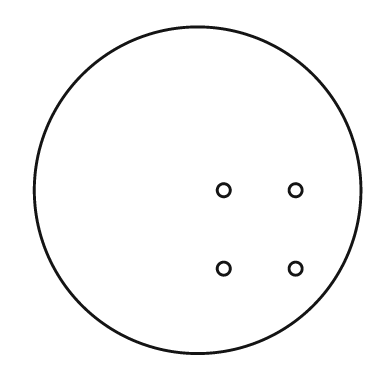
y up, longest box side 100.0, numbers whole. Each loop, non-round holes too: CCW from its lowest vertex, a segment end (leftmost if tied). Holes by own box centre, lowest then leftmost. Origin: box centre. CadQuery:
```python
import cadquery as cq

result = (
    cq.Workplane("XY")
    .moveTo(0.0, 0.0)
    .circle(50.0)
    .moveTo(8.0, -24.0)
    .circle(2.0)
    .moveTo(30.0, -24.0)
    .circle(2.0)
    .moveTo(8.0, 0.0)
    .circle(2.0)
    .moveTo(30.0, 0.0)
    .circle(2.0)
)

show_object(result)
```